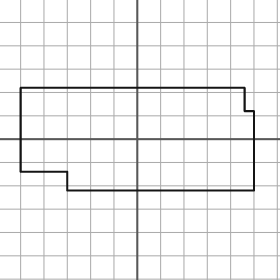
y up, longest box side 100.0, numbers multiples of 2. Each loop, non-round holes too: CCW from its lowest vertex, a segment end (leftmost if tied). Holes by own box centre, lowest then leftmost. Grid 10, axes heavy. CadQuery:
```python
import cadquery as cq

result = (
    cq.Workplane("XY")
    .moveTo(-30.0, -22.0)
    .lineTo(50.0, -22.0)
    .lineTo(50.0, 12.0)
    .lineTo(46.0, 12.0)
    .lineTo(46.0, 22.0)
    .lineTo(-50.0, 22.0)
    .lineTo(-50.0, -14.0)
    .lineTo(-30.0, -14.0)
    .close()
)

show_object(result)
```